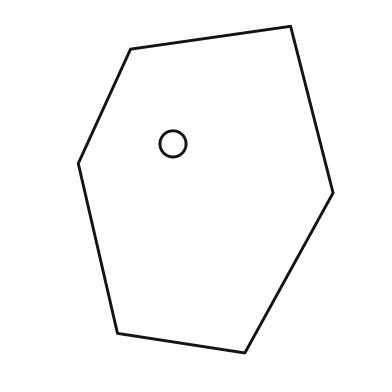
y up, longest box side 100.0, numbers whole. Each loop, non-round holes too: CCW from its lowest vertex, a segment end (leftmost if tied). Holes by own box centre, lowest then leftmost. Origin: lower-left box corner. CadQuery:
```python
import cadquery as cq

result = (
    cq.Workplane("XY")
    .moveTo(51.0, 0.0)
    .lineTo(78.0, 49.0)
    .lineTo(65.0, 100.0)
    .lineTo(16.0, 93.0)
    .lineTo(0.0, 58.0)
    .lineTo(12.0, 6.0)
    .close()
    .moveTo(29.0, 64.0)
    .circle(4.0)
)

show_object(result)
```